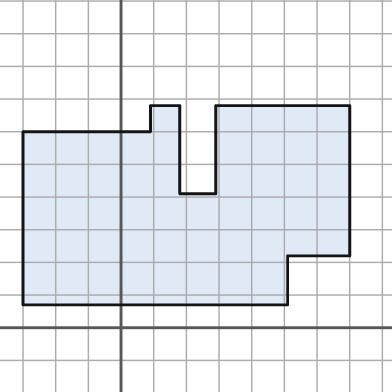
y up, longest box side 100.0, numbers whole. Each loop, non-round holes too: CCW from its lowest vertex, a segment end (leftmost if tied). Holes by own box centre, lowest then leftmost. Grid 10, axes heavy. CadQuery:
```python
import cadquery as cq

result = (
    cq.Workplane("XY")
    .moveTo(-30.0, 7.0)
    .lineTo(51.0, 7.0)
    .lineTo(51.0, 22.0)
    .lineTo(70.0, 22.0)
    .lineTo(70.0, 68.0)
    .lineTo(29.0, 68.0)
    .lineTo(29.0, 41.0)
    .lineTo(18.0, 41.0)
    .lineTo(18.0, 68.0)
    .lineTo(9.0, 68.0)
    .lineTo(9.0, 60.0)
    .lineTo(-30.0, 60.0)
    .close()
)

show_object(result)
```